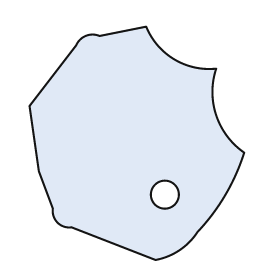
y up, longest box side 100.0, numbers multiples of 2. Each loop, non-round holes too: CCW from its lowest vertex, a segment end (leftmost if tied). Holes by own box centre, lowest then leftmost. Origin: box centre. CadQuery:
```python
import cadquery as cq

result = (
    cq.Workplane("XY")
    .moveTo(8.0, -50.0)
    .threePointArc((18.0, -46.0), (26.0, -38.0))
    .threePointArc((38.0, -22.0), (46.0, -4.0))
    .threePointArc((34.0, 12.0), (34.0, 32.0))
    .threePointArc((16.0, 36.0), (4.0, 50.0))
    .lineTo(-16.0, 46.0)
    .threePointArc((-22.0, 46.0), (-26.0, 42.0))
    .lineTo(-46.0, 16.0)
    .lineTo(-42.0, -12.0)
    .lineTo(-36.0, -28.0)
    .threePointArc((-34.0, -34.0), (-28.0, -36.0))
    .close()
    .moveTo(12.0, -22.0)
    .circle(6.0)
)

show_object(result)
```